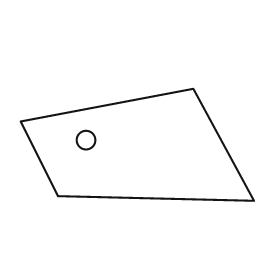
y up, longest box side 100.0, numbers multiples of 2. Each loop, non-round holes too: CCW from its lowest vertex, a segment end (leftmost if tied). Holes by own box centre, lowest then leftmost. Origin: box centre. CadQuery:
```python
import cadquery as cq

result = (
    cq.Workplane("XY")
    .moveTo(50.0, -24.0)
    .lineTo(24.0, 24.0)
    .lineTo(-50.0, 10.0)
    .lineTo(-34.0, -22.0)
    .close()
    .moveTo(-22.0, 2.0)
    .circle(4.0)
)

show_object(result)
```